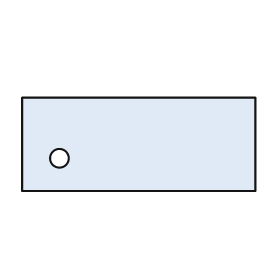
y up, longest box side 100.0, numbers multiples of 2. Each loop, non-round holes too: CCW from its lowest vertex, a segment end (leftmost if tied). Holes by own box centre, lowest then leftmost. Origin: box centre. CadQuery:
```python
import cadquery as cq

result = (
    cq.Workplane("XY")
    .moveTo(-50.0, -20.0)
    .lineTo(50.0, -20.0)
    .lineTo(50.0, 20.0)
    .lineTo(-50.0, 20.0)
    .close()
    .moveTo(-34.0, -6.0)
    .circle(4.0)
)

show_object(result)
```